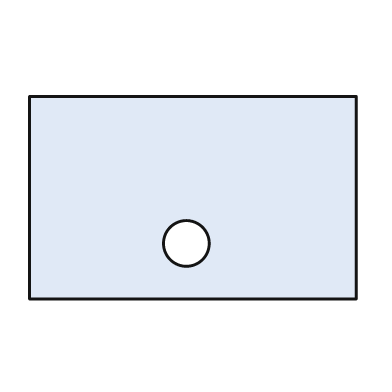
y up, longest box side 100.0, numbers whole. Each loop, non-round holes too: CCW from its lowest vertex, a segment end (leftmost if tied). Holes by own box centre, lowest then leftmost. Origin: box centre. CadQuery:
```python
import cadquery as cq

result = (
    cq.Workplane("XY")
    .moveTo(-50.0, -31.0)
    .lineTo(50.0, -31.0)
    .lineTo(50.0, 31.0)
    .lineTo(-50.0, 31.0)
    .close()
    .moveTo(-2.0, -14.0)
    .circle(7.0)
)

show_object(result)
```